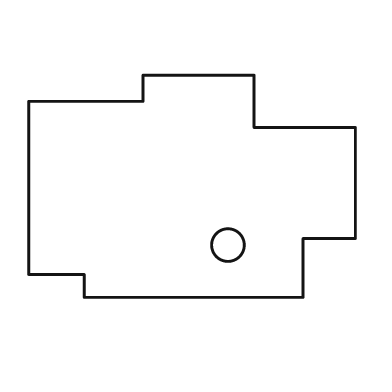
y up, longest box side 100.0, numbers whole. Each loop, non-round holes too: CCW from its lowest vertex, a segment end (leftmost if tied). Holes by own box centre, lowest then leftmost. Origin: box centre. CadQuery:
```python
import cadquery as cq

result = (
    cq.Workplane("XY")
    .moveTo(-33.0, -34.0)
    .lineTo(34.0, -34.0)
    .lineTo(34.0, -16.0)
    .lineTo(50.0, -16.0)
    .lineTo(50.0, 18.0)
    .lineTo(19.0, 18.0)
    .lineTo(19.0, 34.0)
    .lineTo(-15.0, 34.0)
    .lineTo(-15.0, 26.0)
    .lineTo(-50.0, 26.0)
    .lineTo(-50.0, -27.0)
    .lineTo(-33.0, -27.0)
    .close()
    .moveTo(11.0, -18.0)
    .circle(5.0)
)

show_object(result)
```